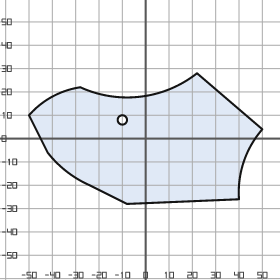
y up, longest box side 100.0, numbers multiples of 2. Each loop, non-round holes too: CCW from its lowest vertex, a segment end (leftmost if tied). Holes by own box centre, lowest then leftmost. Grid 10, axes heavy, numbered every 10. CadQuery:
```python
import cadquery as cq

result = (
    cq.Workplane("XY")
    .moveTo(-8.0, -28.0)
    .lineTo(40.0, -26.0)
    .threePointArc((42.0, -10.0), (50.0, 4.0))
    .lineTo(22.0, 28.0)
    .threePointArc((-2.0, 18.0), (-28.0, 22.0))
    .threePointArc((-40.0, 18.0), (-50.0, 10.0))
    .lineTo(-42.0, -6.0)
    .threePointArc((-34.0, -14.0), (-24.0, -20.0))
    .close()
    .moveTo(-10.0, 8.0)
    .circle(2.0)
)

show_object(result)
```